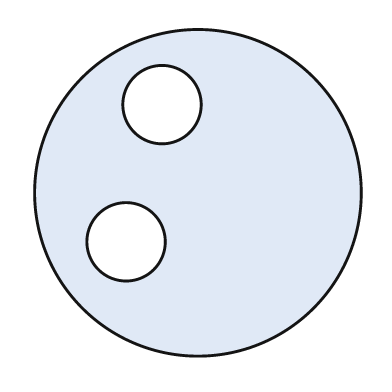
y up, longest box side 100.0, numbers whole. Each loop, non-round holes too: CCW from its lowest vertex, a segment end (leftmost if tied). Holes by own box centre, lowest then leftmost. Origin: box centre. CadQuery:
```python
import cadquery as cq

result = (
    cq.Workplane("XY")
    .moveTo(0.0, 0.0)
    .circle(50.0)
    .moveTo(-22.0, -15.0)
    .circle(12.0)
    .moveTo(-11.0, 27.0)
    .circle(12.0)
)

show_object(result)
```